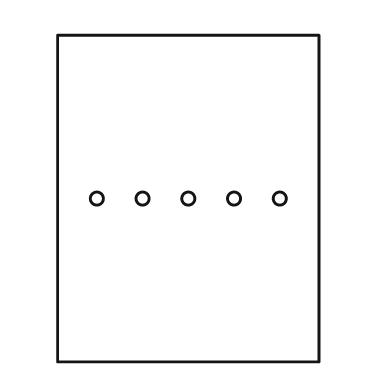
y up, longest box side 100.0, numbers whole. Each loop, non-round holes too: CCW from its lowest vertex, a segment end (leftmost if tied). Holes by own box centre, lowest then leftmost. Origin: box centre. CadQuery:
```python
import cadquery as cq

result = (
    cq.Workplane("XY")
    .moveTo(-40.0, -50.0)
    .lineTo(40.0, -50.0)
    .lineTo(40.0, 50.0)
    .lineTo(-40.0, 50.0)
    .close()
    .moveTo(-28.0, 0.0)
    .circle(2.0)
    .moveTo(-14.0, 0.0)
    .circle(2.0)
    .moveTo(0.0, 0.0)
    .circle(2.0)
    .moveTo(14.0, 0.0)
    .circle(2.0)
    .moveTo(28.0, 0.0)
    .circle(2.0)
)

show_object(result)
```